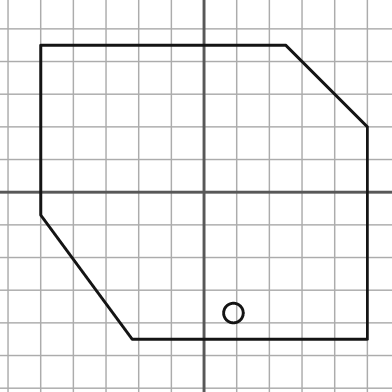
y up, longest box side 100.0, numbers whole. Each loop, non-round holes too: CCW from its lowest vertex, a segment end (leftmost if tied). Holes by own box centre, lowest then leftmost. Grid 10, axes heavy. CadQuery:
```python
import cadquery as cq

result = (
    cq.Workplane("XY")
    .moveTo(-22.0, -45.0)
    .lineTo(50.0, -45.0)
    .lineTo(50.0, 20.0)
    .lineTo(25.0, 45.0)
    .lineTo(-50.0, 45.0)
    .lineTo(-50.0, -7.0)
    .close()
    .moveTo(9.0, -37.0)
    .circle(3.0)
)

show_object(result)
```